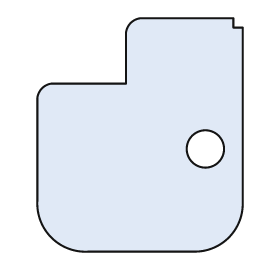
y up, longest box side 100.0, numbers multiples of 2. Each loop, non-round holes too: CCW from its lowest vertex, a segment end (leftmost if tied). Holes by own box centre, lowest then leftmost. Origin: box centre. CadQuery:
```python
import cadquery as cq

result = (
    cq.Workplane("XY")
    .moveTo(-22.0, -50.0)
    .lineTo(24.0, -50.0)
    .threePointArc((38.0, -44.0), (44.0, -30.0))
    .lineTo(44.0, 46.0)
    .lineTo(40.0, 46.0)
    .lineTo(40.0, 50.0)
    .lineTo(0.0, 50.0)
    .threePointArc((-4.0, 48.0), (-6.0, 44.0))
    .lineTo(-6.0, 22.0)
    .lineTo(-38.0, 22.0)
    .threePointArc((-42.0, 20.0), (-44.0, 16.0))
    .lineTo(-44.0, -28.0)
    .threePointArc((-38.0, -44.0), (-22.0, -50.0))
    .close()
    .moveTo(28.0, -6.0)
    .circle(8.0)
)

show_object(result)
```